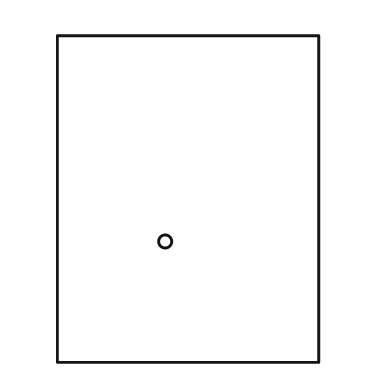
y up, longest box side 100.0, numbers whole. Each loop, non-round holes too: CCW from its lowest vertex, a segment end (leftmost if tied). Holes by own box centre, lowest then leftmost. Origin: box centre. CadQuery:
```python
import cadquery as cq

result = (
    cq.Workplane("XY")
    .moveTo(-40.0, -50.0)
    .lineTo(40.0, -50.0)
    .lineTo(40.0, 50.0)
    .lineTo(-40.0, 50.0)
    .close()
    .moveTo(-7.0, -13.0)
    .circle(2.0)
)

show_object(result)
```